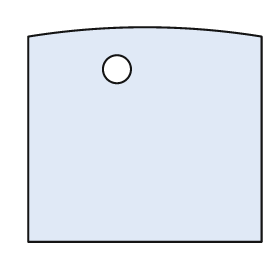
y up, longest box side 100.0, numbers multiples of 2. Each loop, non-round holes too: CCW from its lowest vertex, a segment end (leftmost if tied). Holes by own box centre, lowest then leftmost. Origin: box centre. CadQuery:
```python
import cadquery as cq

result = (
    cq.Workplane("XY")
    .moveTo(-50.0, -46.0)
    .lineTo(50.0, -46.0)
    .lineTo(50.0, 42.0)
    .threePointArc((0.0, 46.0), (-50.0, 42.0))
    .close()
    .moveTo(-12.0, 28.0)
    .circle(6.0)
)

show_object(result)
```